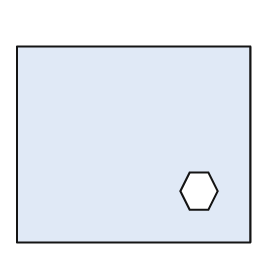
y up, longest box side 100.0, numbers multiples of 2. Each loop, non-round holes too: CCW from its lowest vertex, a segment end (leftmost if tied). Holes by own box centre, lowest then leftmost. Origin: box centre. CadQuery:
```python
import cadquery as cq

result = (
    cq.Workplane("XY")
    .moveTo(-50.0, -42.0)
    .lineTo(50.0, -42.0)
    .lineTo(50.0, 42.0)
    .lineTo(-50.0, 42.0)
    .close()
    .moveTo(24.0, -28.0)
    .lineTo(32.0, -28.0)
    .lineTo(36.0, -20.0)
    .lineTo(32.0, -12.0)
    .lineTo(24.0, -12.0)
    .lineTo(20.0, -20.0)
    .close()
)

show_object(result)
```